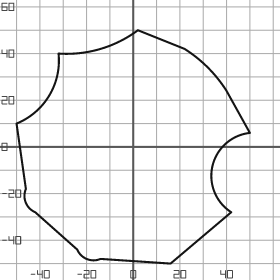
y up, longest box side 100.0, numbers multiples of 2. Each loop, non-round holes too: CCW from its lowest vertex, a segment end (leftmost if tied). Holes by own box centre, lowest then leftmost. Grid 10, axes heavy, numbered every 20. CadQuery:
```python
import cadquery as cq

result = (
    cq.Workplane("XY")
    .moveTo(16.0, -50.0)
    .lineTo(42.0, -28.0)
    .threePointArc((34.0, -8.0), (50.0, 6.0))
    .lineTo(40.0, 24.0)
    .threePointArc((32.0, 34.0), (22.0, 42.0))
    .lineTo(2.0, 50.0)
    .threePointArc((-14.0, 42.0), (-32.0, 40.0))
    .threePointArc((-36.0, 22.0), (-50.0, 10.0))
    .lineTo(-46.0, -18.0)
    .threePointArc((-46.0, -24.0), (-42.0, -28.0))
    .lineTo(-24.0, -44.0)
    .threePointArc((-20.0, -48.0), (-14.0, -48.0))
    .close()
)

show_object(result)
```